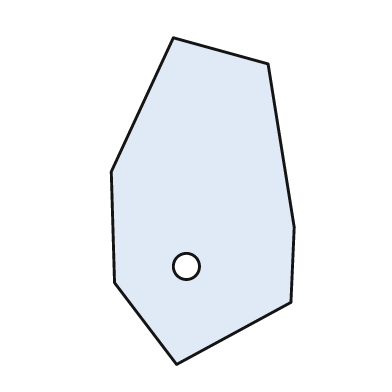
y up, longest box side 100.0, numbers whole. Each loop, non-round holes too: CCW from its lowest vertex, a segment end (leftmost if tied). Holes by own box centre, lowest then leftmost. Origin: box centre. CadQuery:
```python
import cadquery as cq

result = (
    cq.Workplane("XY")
    .moveTo(-8.0, -50.0)
    .lineTo(27.0, -31.0)
    .lineTo(28.0, -8.0)
    .lineTo(20.0, 42.0)
    .lineTo(-9.0, 50.0)
    .lineTo(-28.0, 9.0)
    .lineTo(-27.0, -25.0)
    .close()
    .moveTo(-5.0, -20.0)
    .circle(4.0)
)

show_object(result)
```